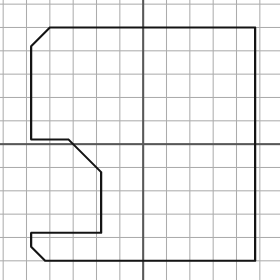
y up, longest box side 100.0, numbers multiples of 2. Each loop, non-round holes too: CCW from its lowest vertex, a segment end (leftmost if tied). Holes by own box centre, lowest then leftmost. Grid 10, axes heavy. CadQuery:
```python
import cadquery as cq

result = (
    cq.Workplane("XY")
    .moveTo(-42.0, -50.0)
    .lineTo(48.0, -50.0)
    .lineTo(48.0, 50.0)
    .lineTo(-40.0, 50.0)
    .lineTo(-48.0, 42.0)
    .lineTo(-48.0, 2.0)
    .lineTo(-32.0, 2.0)
    .lineTo(-18.0, -12.0)
    .lineTo(-18.0, -38.0)
    .lineTo(-48.0, -38.0)
    .lineTo(-48.0, -44.0)
    .close()
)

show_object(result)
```